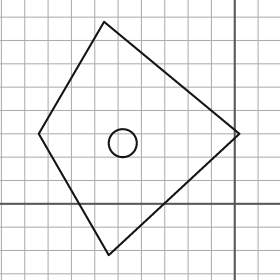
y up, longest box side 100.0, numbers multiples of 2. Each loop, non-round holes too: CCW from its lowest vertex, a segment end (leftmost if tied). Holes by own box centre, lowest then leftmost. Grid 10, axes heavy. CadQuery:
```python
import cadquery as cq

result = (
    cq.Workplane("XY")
    .moveTo(-54.0, -22.0)
    .lineTo(2.0, 30.0)
    .lineTo(-56.0, 78.0)
    .lineTo(-84.0, 30.0)
    .close()
    .moveTo(-48.0, 26.0)
    .circle(6.0)
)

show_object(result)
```